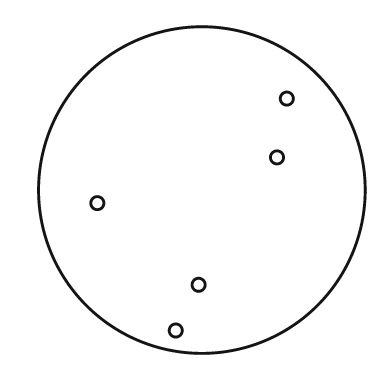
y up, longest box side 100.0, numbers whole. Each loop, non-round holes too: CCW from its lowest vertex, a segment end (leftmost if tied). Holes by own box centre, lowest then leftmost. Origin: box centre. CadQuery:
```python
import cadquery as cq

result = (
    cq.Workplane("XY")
    .moveTo(0.0, 0.0)
    .circle(50.0)
    .moveTo(-8.0, -43.0)
    .circle(2.0)
    .moveTo(-1.0, -29.0)
    .circle(2.0)
    .moveTo(-32.0, -4.0)
    .circle(2.0)
    .moveTo(23.0, 10.0)
    .circle(2.0)
    .moveTo(26.0, 28.0)
    .circle(2.0)
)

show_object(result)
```